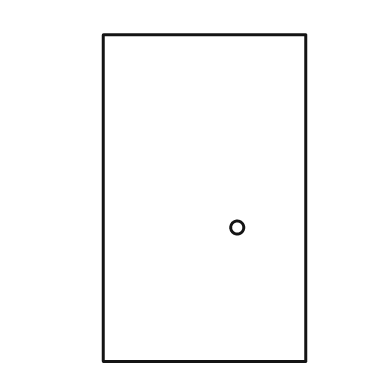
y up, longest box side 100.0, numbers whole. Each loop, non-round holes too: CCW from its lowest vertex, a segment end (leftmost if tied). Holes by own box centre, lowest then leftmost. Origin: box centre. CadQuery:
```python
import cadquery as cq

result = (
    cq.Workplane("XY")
    .moveTo(-31.0, -50.0)
    .lineTo(31.0, -50.0)
    .lineTo(31.0, 50.0)
    .lineTo(-31.0, 50.0)
    .close()
    .moveTo(10.0, -9.0)
    .circle(2.0)
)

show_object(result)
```